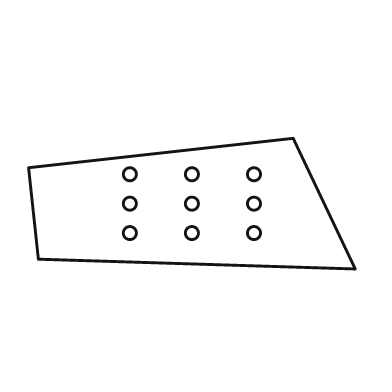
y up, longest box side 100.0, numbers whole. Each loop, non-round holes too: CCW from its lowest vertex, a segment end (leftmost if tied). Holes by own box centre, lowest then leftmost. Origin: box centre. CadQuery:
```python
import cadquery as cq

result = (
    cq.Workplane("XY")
    .moveTo(50.0, -20.0)
    .lineTo(31.0, 20.0)
    .lineTo(-50.0, 11.0)
    .lineTo(-47.0, -17.0)
    .close()
    .moveTo(-19.0, -9.0)
    .circle(2.0)
    .moveTo(0.0, -9.0)
    .circle(2.0)
    .moveTo(19.0, -9.0)
    .circle(2.0)
    .moveTo(-19.0, 0.0)
    .circle(2.0)
    .moveTo(0.0, 0.0)
    .circle(2.0)
    .moveTo(19.0, 0.0)
    .circle(2.0)
    .moveTo(-19.0, 9.0)
    .circle(2.0)
    .moveTo(0.0, 9.0)
    .circle(2.0)
    .moveTo(19.0, 9.0)
    .circle(2.0)
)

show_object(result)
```